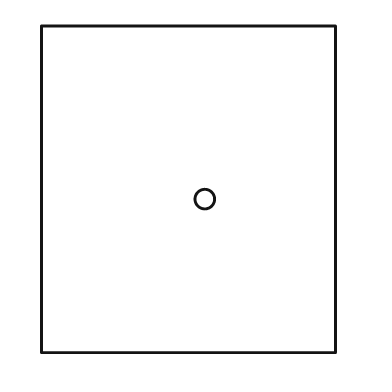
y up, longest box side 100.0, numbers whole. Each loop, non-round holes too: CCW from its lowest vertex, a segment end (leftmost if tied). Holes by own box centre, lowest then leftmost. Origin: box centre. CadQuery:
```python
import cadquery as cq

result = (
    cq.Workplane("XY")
    .moveTo(-45.0, -50.0)
    .lineTo(45.0, -50.0)
    .lineTo(45.0, 50.0)
    .lineTo(-45.0, 50.0)
    .close()
    .moveTo(5.0, -3.0)
    .circle(3.0)
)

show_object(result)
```